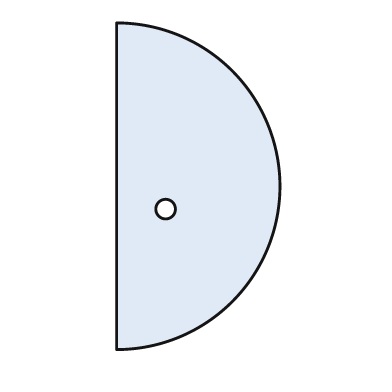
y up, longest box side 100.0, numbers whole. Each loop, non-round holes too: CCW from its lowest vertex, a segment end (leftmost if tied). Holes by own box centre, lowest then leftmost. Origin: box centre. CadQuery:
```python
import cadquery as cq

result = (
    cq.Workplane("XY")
    .moveTo(-25.0, -50.0)
    .threePointArc((25.0, 0.0), (-25.0, 50.0))
    .close()
    .moveTo(-10.0, -7.0)
    .circle(3.0)
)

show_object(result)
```